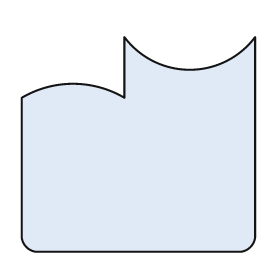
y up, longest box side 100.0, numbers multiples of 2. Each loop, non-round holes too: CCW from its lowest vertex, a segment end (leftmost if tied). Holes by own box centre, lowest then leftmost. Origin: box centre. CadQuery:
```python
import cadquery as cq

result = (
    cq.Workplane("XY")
    .moveTo(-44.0, -46.0)
    .lineTo(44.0, -46.0)
    .threePointArc((48.0, -44.0), (50.0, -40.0))
    .lineTo(50.0, 46.0)
    .threePointArc((22.0, 32.0), (-6.0, 46.0))
    .lineTo(-6.0, 20.0)
    .threePointArc((-28.0, 26.0), (-50.0, 20.0))
    .lineTo(-50.0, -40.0)
    .threePointArc((-48.0, -44.0), (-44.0, -46.0))
    .close()
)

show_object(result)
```